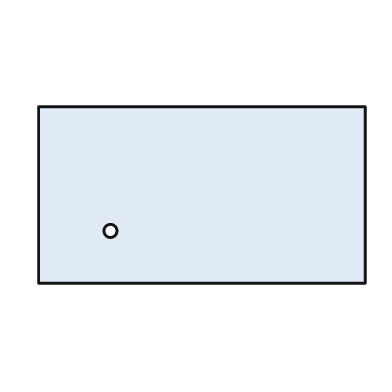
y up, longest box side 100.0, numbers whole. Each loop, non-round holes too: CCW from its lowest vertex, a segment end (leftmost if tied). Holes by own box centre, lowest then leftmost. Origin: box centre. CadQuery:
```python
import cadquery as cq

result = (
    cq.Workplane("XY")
    .moveTo(-50.0, -27.0)
    .lineTo(50.0, -27.0)
    .lineTo(50.0, 27.0)
    .lineTo(-50.0, 27.0)
    .close()
    .moveTo(-28.0, -11.0)
    .circle(2.0)
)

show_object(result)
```